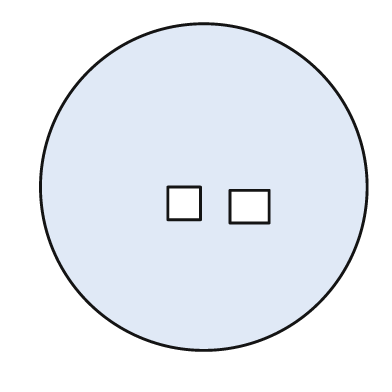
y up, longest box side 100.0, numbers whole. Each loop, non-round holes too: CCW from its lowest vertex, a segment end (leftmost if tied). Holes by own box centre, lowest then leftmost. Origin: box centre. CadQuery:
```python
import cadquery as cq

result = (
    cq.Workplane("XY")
    .moveTo(0.0, 0.0)
    .circle(50.0)
    .moveTo(8.0, -11.0)
    .lineTo(20.0, -11.0)
    .lineTo(20.0, -1.0)
    .lineTo(8.0, -1.0)
    .close()
    .moveTo(-11.0, -10.0)
    .lineTo(-1.0, -10.0)
    .lineTo(-1.0, 0.0)
    .lineTo(-11.0, 0.0)
    .close()
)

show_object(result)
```